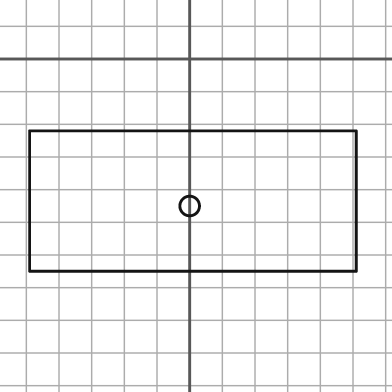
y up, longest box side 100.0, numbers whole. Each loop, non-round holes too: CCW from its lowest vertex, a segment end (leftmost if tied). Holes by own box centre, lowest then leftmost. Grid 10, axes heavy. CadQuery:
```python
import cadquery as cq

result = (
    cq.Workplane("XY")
    .moveTo(-49.0, -65.0)
    .lineTo(51.0, -65.0)
    .lineTo(51.0, -22.0)
    .lineTo(-49.0, -22.0)
    .close()
    .moveTo(0.0, -45.0)
    .circle(3.0)
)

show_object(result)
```